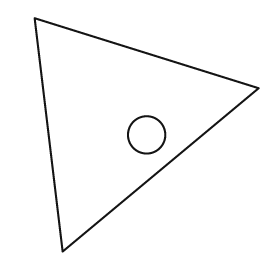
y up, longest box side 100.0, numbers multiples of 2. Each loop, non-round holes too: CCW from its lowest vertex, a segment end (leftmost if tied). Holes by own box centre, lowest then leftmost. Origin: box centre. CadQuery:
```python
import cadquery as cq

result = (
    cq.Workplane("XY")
    .moveTo(-36.0, -50.0)
    .lineTo(48.0, 20.0)
    .lineTo(-48.0, 50.0)
    .close()
    .moveTo(0.0, 0.0)
    .circle(8.0)
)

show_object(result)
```